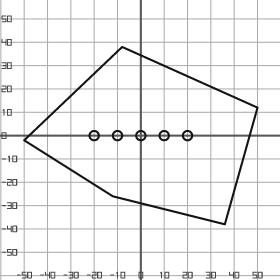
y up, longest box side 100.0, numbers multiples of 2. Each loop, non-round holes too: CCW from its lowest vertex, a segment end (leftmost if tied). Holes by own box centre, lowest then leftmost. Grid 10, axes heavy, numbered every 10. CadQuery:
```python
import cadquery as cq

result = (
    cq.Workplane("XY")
    .moveTo(36.0, -38.0)
    .lineTo(50.0, 12.0)
    .lineTo(-8.0, 38.0)
    .lineTo(-50.0, -2.0)
    .lineTo(-12.0, -26.0)
    .close()
    .moveTo(-20.0, 0.0)
    .circle(2.0)
    .moveTo(-10.0, 0.0)
    .circle(2.0)
    .moveTo(0.0, 0.0)
    .circle(2.0)
    .moveTo(10.0, 0.0)
    .circle(2.0)
    .moveTo(20.0, 0.0)
    .circle(2.0)
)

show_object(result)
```